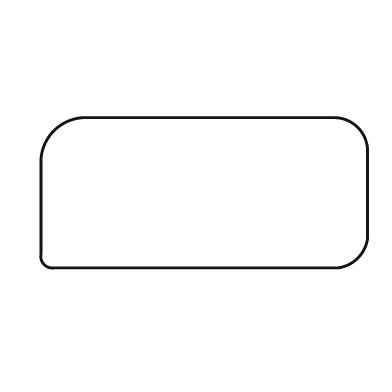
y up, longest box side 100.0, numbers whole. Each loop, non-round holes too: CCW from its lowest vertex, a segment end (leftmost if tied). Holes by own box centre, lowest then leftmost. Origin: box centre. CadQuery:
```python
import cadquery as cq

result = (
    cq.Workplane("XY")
    .moveTo(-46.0, -23.0)
    .lineTo(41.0, -23.0)
    .threePointArc((47.0, -20.0), (50.0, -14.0))
    .lineTo(50.0, 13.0)
    .threePointArc((47.0, 20.0), (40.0, 23.0))
    .lineTo(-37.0, 23.0)
    .threePointArc((-46.0, 19.0), (-50.0, 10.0))
    .lineTo(-50.0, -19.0)
    .threePointArc((-49.0, -22.0), (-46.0, -23.0))
    .close()
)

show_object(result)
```